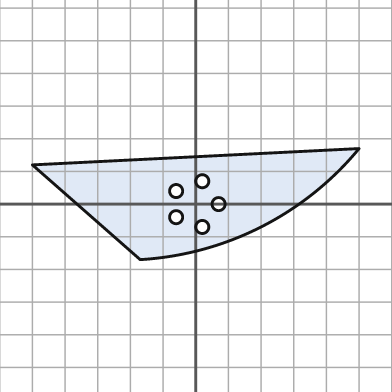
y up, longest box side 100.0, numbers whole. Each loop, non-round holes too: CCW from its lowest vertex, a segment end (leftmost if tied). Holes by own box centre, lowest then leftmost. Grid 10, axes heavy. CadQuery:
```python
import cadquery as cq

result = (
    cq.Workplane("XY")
    .moveTo(-17.0, -17.0)
    .threePointArc((20.0, -7.0), (50.0, 17.0))
    .lineTo(-50.0, 12.0)
    .close()
    .moveTo(2.0, -7.0)
    .circle(2.0)
    .moveTo(-6.0, -4.0)
    .circle(2.0)
    .moveTo(7.0, 0.0)
    .circle(2.0)
    .moveTo(-6.0, 4.0)
    .circle(2.0)
    .moveTo(2.0, 7.0)
    .circle(2.0)
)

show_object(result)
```